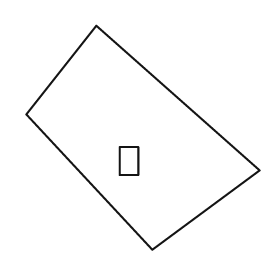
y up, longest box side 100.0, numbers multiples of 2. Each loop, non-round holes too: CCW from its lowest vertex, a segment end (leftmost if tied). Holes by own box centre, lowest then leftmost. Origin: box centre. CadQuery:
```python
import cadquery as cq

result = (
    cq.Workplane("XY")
    .moveTo(4.0, -48.0)
    .lineTo(50.0, -14.0)
    .lineTo(-20.0, 48.0)
    .lineTo(-50.0, 10.0)
    .close()
    .moveTo(-10.0, -16.0)
    .lineTo(-2.0, -16.0)
    .lineTo(-2.0, -4.0)
    .lineTo(-10.0, -4.0)
    .close()
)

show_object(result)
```